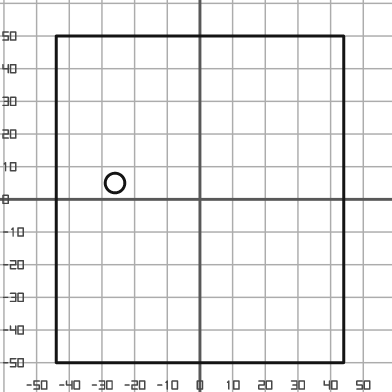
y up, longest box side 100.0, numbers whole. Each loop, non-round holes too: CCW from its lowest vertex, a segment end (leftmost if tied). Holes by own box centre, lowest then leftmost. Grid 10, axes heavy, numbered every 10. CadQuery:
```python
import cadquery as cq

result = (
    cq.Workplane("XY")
    .moveTo(-44.0, -50.0)
    .lineTo(44.0, -50.0)
    .lineTo(44.0, 50.0)
    .lineTo(-44.0, 50.0)
    .close()
    .moveTo(-26.0, 5.0)
    .circle(3.0)
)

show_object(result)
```